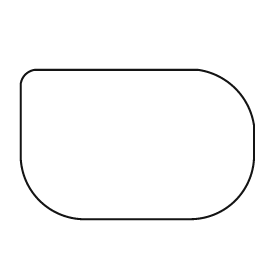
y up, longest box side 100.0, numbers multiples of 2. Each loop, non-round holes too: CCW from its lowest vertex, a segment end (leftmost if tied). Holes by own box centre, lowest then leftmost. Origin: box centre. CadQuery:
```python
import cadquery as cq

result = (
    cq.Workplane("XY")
    .moveTo(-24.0, -32.0)
    .lineTo(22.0, -32.0)
    .threePointArc((42.0, -24.0), (50.0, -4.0))
    .lineTo(50.0, 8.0)
    .threePointArc((42.0, 24.0), (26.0, 32.0))
    .lineTo(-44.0, 32.0)
    .threePointArc((-48.0, 30.0), (-50.0, 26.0))
    .lineTo(-50.0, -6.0)
    .threePointArc((-42.0, -24.0), (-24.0, -32.0))
    .close()
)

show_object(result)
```